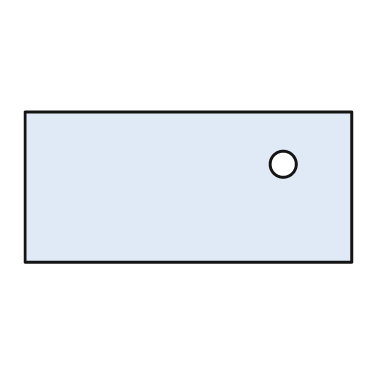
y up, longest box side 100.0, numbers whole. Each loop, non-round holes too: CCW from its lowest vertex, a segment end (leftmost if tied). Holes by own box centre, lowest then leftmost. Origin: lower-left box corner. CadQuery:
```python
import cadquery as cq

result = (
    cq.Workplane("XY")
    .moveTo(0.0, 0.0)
    .lineTo(100.0, 0.0)
    .lineTo(100.0, 46.0)
    .lineTo(0.0, 46.0)
    .close()
    .moveTo(79.0, 30.0)
    .circle(4.0)
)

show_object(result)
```